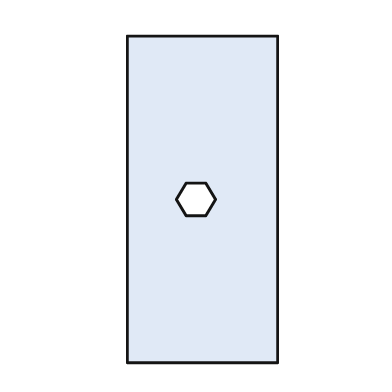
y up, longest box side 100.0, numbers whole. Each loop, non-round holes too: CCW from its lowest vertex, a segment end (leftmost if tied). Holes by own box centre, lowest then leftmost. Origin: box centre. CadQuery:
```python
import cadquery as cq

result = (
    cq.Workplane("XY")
    .moveTo(-23.0, -50.0)
    .lineTo(23.0, -50.0)
    .lineTo(23.0, 50.0)
    .lineTo(-23.0, 50.0)
    .close()
    .moveTo(-5.0, -5.0)
    .lineTo(1.0, -5.0)
    .lineTo(4.0, 0.0)
    .lineTo(1.0, 5.0)
    .lineTo(-5.0, 5.0)
    .lineTo(-8.0, 0.0)
    .close()
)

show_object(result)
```